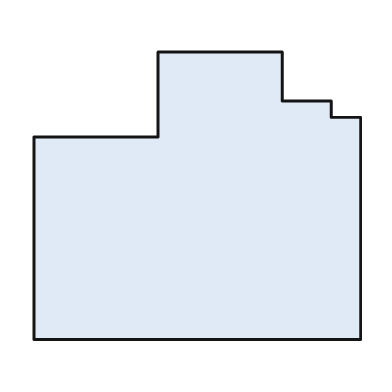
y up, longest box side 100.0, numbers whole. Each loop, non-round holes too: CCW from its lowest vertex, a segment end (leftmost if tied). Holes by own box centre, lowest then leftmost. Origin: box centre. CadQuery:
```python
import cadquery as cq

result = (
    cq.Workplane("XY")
    .moveTo(-50.0, -44.0)
    .lineTo(50.0, -44.0)
    .lineTo(50.0, 24.0)
    .lineTo(41.0, 24.0)
    .lineTo(41.0, 29.0)
    .lineTo(26.0, 29.0)
    .lineTo(26.0, 44.0)
    .lineTo(-12.0, 44.0)
    .lineTo(-12.0, 18.0)
    .lineTo(-50.0, 18.0)
    .close()
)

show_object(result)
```